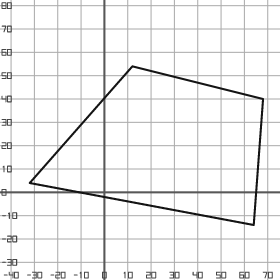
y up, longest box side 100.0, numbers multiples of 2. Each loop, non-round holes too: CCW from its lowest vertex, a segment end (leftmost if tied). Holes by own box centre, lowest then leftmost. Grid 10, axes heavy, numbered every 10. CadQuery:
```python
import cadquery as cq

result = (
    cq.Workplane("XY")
    .moveTo(64.0, -14.0)
    .lineTo(68.0, 40.0)
    .lineTo(12.0, 54.0)
    .lineTo(-32.0, 4.0)
    .close()
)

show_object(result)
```